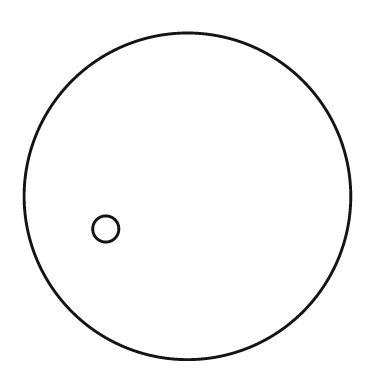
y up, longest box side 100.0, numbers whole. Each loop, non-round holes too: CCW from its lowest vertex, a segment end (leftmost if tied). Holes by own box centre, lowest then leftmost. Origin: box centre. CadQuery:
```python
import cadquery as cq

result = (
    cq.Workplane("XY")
    .moveTo(0.0, 0.0)
    .circle(50.0)
    .moveTo(-25.0, -10.0)
    .circle(4.0)
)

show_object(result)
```